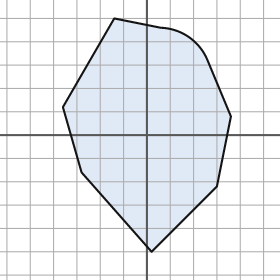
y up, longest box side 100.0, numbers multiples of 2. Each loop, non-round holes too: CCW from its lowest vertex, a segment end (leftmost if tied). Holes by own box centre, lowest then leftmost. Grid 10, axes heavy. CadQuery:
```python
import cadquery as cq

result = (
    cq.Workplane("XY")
    .moveTo(2.0, -50.0)
    .lineTo(30.0, -22.0)
    .lineTo(36.0, 8.0)
    .lineTo(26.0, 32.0)
    .threePointArc((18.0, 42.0), (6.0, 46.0))
    .lineTo(-14.0, 50.0)
    .lineTo(-36.0, 12.0)
    .lineTo(-28.0, -16.0)
    .close()
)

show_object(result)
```